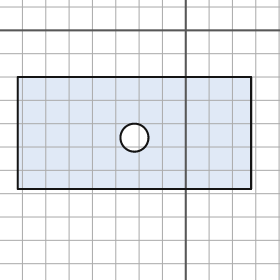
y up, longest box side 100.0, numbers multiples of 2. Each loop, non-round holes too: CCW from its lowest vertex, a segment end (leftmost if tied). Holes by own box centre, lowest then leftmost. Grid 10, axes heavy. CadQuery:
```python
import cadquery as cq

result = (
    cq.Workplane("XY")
    .moveTo(-72.0, -68.0)
    .lineTo(28.0, -68.0)
    .lineTo(28.0, -20.0)
    .lineTo(-72.0, -20.0)
    .close()
    .moveTo(-22.0, -46.0)
    .circle(6.0)
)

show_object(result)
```